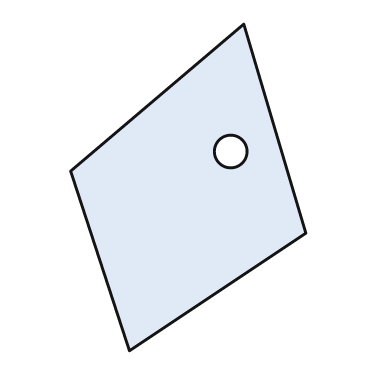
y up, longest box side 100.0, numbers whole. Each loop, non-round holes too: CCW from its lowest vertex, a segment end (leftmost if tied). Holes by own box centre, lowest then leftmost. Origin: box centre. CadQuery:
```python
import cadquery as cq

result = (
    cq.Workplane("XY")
    .moveTo(-18.0, -50.0)
    .lineTo(36.0, -14.0)
    .lineTo(17.0, 50.0)
    .lineTo(-36.0, 5.0)
    .close()
    .moveTo(13.0, 11.0)
    .circle(5.0)
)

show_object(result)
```